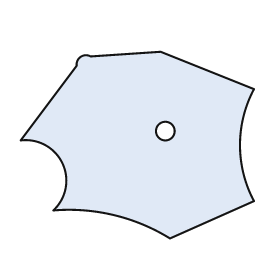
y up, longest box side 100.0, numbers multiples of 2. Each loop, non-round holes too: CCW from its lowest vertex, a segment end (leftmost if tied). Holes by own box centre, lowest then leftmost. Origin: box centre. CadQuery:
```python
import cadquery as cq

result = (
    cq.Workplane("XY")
    .moveTo(14.0, -40.0)
    .lineTo(50.0, -24.0)
    .threePointArc((44.0, 0.0), (50.0, 24.0))
    .lineTo(10.0, 40.0)
    .lineTo(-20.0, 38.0)
    .threePointArc((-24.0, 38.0), (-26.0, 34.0))
    .lineTo(-50.0, 2.0)
    .threePointArc((-32.0, -8.0), (-36.0, -28.0))
    .threePointArc((-10.0, -30.0), (14.0, -40.0))
    .close()
    .moveTo(12.0, 6.0)
    .circle(4.0)
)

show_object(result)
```